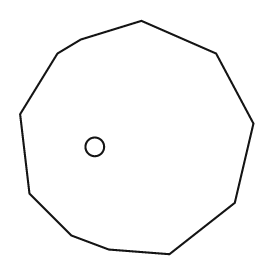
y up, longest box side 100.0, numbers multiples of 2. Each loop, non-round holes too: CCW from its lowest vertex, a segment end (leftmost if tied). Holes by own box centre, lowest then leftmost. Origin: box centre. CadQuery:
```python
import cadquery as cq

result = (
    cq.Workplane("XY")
    .moveTo(14.0, -50.0)
    .lineTo(42.0, -28.0)
    .lineTo(50.0, 6.0)
    .lineTo(34.0, 36.0)
    .lineTo(2.0, 50.0)
    .lineTo(-24.0, 42.0)
    .lineTo(-34.0, 36.0)
    .lineTo(-50.0, 10.0)
    .lineTo(-46.0, -24.0)
    .lineTo(-28.0, -42.0)
    .lineTo(-12.0, -48.0)
    .close()
    .moveTo(-18.0, -4.0)
    .circle(4.0)
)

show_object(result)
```